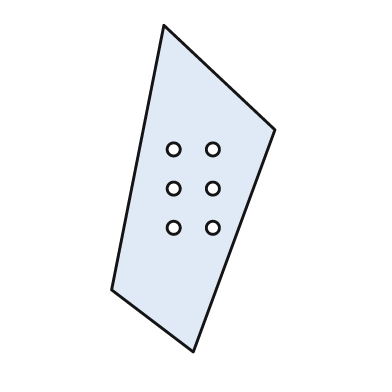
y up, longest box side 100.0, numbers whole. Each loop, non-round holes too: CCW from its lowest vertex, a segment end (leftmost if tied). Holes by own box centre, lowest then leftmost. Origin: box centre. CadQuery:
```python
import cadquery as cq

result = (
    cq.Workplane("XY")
    .moveTo(0.0, -50.0)
    .lineTo(25.0, 18.0)
    .lineTo(-9.0, 50.0)
    .lineTo(-25.0, -31.0)
    .close()
    .moveTo(-6.0, -12.0)
    .circle(2.0)
    .moveTo(6.0, -12.0)
    .circle(2.0)
    .moveTo(-6.0, 0.0)
    .circle(2.0)
    .moveTo(6.0, 0.0)
    .circle(2.0)
    .moveTo(-6.0, 12.0)
    .circle(2.0)
    .moveTo(6.0, 12.0)
    .circle(2.0)
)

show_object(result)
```